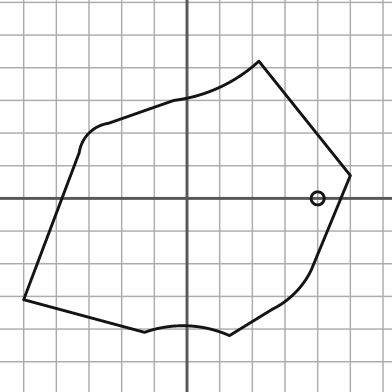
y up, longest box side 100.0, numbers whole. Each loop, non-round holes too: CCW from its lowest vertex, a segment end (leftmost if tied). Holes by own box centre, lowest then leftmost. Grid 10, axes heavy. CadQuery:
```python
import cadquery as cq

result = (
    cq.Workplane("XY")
    .moveTo(13.0, -42.0)
    .lineTo(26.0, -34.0)
    .threePointArc((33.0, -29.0), (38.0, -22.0))
    .lineTo(50.0, 7.0)
    .lineTo(22.0, 42.0)
    .threePointArc((10.0, 34.0), (-4.0, 30.0))
    .lineTo(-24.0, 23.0)
    .threePointArc((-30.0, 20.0), (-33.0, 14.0))
    .lineTo(-50.0, -31.0)
    .lineTo(-13.0, -41.0)
    .threePointArc((0.0, -39.0), (13.0, -42.0))
    .close()
    .moveTo(40.0, 0.0)
    .circle(2.0)
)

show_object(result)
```